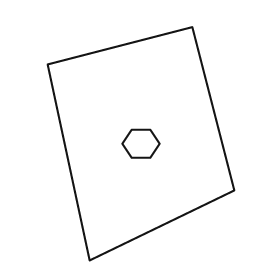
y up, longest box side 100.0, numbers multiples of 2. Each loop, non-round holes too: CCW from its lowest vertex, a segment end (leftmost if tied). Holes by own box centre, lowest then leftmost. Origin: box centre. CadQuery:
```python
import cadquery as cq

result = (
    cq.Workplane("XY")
    .moveTo(-22.0, -50.0)
    .lineTo(40.0, -20.0)
    .lineTo(22.0, 50.0)
    .lineTo(-40.0, 34.0)
    .close()
    .moveTo(-4.0, -6.0)
    .lineTo(4.0, -6.0)
    .lineTo(8.0, 0.0)
    .lineTo(4.0, 6.0)
    .lineTo(-4.0, 6.0)
    .lineTo(-8.0, 0.0)
    .close()
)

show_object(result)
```